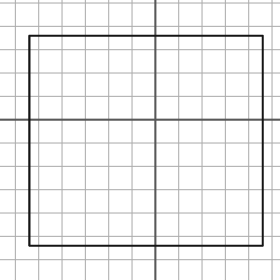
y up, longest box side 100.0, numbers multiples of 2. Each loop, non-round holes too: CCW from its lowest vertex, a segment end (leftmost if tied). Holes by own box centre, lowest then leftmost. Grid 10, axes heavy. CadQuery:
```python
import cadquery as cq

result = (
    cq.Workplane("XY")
    .moveTo(-54.0, -54.0)
    .lineTo(46.0, -54.0)
    .lineTo(46.0, 36.0)
    .lineTo(-54.0, 36.0)
    .close()
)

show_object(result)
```